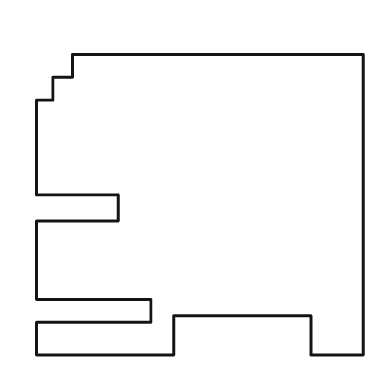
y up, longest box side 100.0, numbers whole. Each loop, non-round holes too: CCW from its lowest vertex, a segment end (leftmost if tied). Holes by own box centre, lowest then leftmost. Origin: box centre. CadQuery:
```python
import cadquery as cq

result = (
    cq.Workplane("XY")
    .moveTo(-50.0, -46.0)
    .lineTo(-8.0, -46.0)
    .lineTo(-8.0, -34.0)
    .lineTo(34.0, -34.0)
    .lineTo(34.0, -46.0)
    .lineTo(50.0, -46.0)
    .lineTo(50.0, 46.0)
    .lineTo(-39.0, 46.0)
    .lineTo(-39.0, 39.0)
    .lineTo(-45.0, 39.0)
    .lineTo(-45.0, 32.0)
    .lineTo(-50.0, 32.0)
    .lineTo(-50.0, 3.0)
    .lineTo(-25.0, 3.0)
    .lineTo(-25.0, -5.0)
    .lineTo(-50.0, -5.0)
    .lineTo(-50.0, -29.0)
    .lineTo(-15.0, -29.0)
    .lineTo(-15.0, -36.0)
    .lineTo(-50.0, -36.0)
    .close()
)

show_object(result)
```